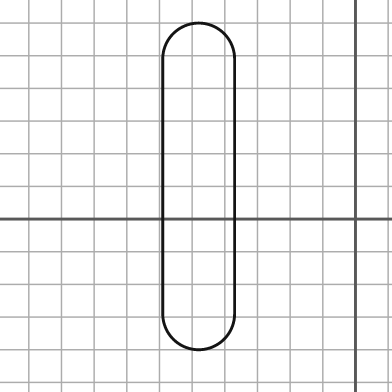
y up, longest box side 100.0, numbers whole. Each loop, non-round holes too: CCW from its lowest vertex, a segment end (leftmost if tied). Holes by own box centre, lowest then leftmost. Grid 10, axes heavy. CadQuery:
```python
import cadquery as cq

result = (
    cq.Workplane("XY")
    .moveTo(-59.0, -29.0)
    .threePointArc((-48.0, -40.0), (-37.0, -29.0))
    .lineTo(-37.0, 49.0)
    .threePointArc((-48.0, 60.0), (-59.0, 49.0))
    .close()
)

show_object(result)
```